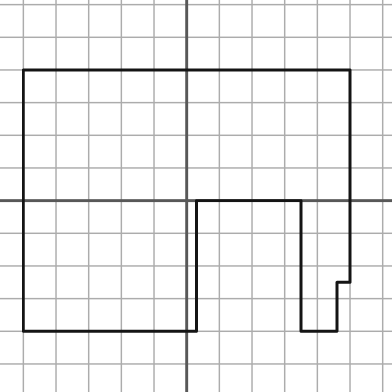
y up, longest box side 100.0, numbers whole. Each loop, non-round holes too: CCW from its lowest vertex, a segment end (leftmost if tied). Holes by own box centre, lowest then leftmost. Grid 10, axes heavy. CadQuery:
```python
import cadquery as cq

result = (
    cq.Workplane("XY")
    .moveTo(-50.0, -40.0)
    .lineTo(3.0, -40.0)
    .lineTo(3.0, 0.0)
    .lineTo(35.0, 0.0)
    .lineTo(35.0, -40.0)
    .lineTo(46.0, -40.0)
    .lineTo(46.0, -25.0)
    .lineTo(50.0, -25.0)
    .lineTo(50.0, 40.0)
    .lineTo(-50.0, 40.0)
    .close()
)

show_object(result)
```